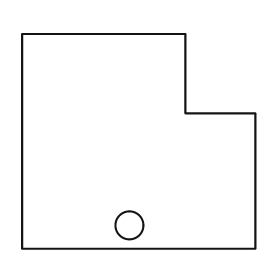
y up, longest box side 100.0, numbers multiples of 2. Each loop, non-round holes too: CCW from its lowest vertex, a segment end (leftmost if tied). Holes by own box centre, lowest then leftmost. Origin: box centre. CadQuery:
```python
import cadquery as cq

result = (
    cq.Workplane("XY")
    .moveTo(-50.0, -46.0)
    .lineTo(50.0, -46.0)
    .lineTo(50.0, 12.0)
    .lineTo(20.0, 12.0)
    .lineTo(20.0, 46.0)
    .lineTo(-50.0, 46.0)
    .close()
    .moveTo(-4.0, -36.0)
    .circle(6.0)
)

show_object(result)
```